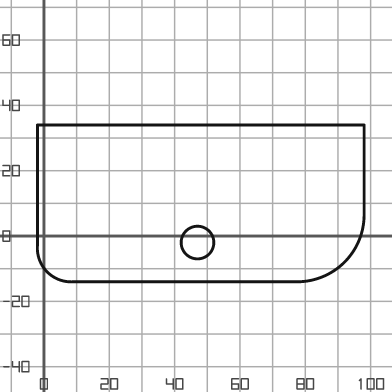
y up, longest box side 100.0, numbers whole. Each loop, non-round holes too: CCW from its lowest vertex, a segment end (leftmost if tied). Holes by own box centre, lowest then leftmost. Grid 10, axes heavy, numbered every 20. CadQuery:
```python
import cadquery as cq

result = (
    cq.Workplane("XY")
    .moveTo(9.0, -14.0)
    .lineTo(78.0, -14.0)
    .threePointArc((92.0, -8.0), (98.0, 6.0))
    .lineTo(98.0, 34.0)
    .lineTo(-2.0, 34.0)
    .lineTo(-2.0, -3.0)
    .threePointArc((1.0, -11.0), (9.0, -14.0))
    .close()
    .moveTo(47.0, -2.0)
    .circle(5.0)
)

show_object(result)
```